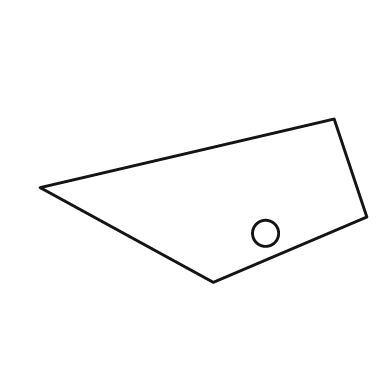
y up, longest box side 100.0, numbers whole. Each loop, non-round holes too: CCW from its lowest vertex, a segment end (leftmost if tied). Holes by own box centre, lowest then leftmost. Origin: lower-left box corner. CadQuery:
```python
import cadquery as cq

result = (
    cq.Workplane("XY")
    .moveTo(53.0, 0.0)
    .lineTo(100.0, 20.0)
    .lineTo(90.0, 50.0)
    .lineTo(0.0, 29.0)
    .close()
    .moveTo(69.0, 15.0)
    .circle(4.0)
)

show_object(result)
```